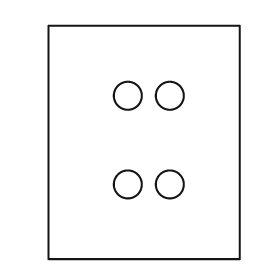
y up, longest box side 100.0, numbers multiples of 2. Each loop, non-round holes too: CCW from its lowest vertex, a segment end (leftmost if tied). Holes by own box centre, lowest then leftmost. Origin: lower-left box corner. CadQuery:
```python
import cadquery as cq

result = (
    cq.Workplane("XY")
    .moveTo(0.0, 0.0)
    .lineTo(82.0, 0.0)
    .lineTo(82.0, 100.0)
    .lineTo(0.0, 100.0)
    .close()
    .moveTo(34.0, 32.0)
    .circle(6.0)
    .moveTo(52.0, 32.0)
    .circle(6.0)
    .moveTo(34.0, 70.0)
    .circle(6.0)
    .moveTo(52.0, 70.0)
    .circle(6.0)
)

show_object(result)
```